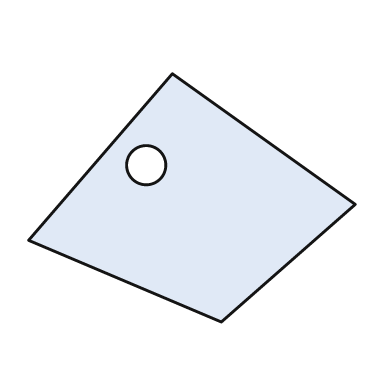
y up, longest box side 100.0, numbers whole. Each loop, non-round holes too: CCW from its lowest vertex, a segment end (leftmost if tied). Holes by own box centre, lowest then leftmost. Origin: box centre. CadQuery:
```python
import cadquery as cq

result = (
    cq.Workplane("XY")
    .moveTo(9.0, -38.0)
    .lineTo(50.0, -2.0)
    .lineTo(-6.0, 38.0)
    .lineTo(-50.0, -13.0)
    .close()
    .moveTo(-14.0, 10.0)
    .circle(6.0)
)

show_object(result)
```